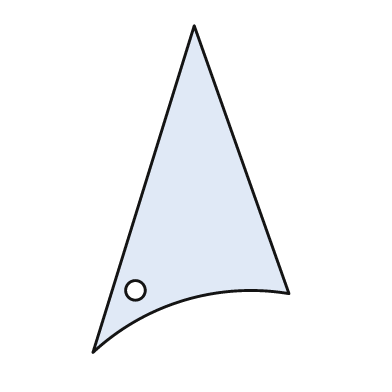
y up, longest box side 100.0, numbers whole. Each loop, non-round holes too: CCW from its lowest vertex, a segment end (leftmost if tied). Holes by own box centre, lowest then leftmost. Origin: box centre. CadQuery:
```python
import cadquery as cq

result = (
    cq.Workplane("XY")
    .moveTo(-30.0, -50.0)
    .threePointArc((-2.0, -34.0), (30.0, -32.0))
    .lineTo(1.0, 50.0)
    .close()
    .moveTo(-17.0, -31.0)
    .circle(3.0)
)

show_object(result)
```